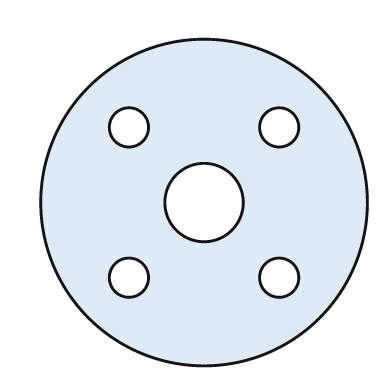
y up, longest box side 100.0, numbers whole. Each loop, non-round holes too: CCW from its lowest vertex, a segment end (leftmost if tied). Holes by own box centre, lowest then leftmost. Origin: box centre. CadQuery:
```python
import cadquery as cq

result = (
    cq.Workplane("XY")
    .moveTo(0.0, 0.0)
    .circle(50.0)
    .moveTo(-23.0, -23.0)
    .circle(6.0)
    .moveTo(23.0, -23.0)
    .circle(6.0)
    .moveTo(0.0, 0.0)
    .circle(12.0)
    .moveTo(-23.0, 23.0)
    .circle(6.0)
    .moveTo(23.0, 23.0)
    .circle(6.0)
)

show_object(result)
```